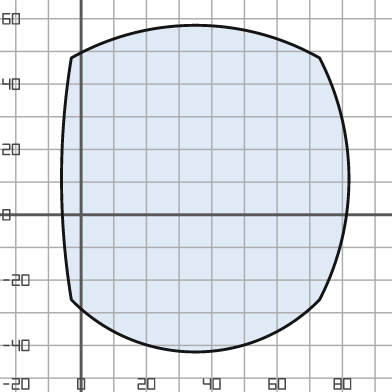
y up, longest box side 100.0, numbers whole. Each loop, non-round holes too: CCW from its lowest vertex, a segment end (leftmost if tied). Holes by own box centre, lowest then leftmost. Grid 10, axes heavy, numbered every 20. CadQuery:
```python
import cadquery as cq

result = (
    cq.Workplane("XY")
    .moveTo(-3.0, -26.0)
    .threePointArc((35.0, -42.0), (73.0, -26.0))
    .threePointArc((82.0, 11.0), (73.0, 48.0))
    .threePointArc((35.0, 58.0), (-3.0, 48.0))
    .threePointArc((-6.0, 11.0), (-3.0, -26.0))
    .close()
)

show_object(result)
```